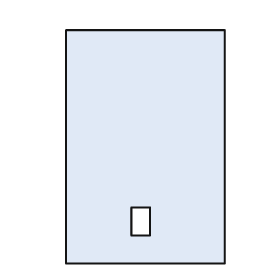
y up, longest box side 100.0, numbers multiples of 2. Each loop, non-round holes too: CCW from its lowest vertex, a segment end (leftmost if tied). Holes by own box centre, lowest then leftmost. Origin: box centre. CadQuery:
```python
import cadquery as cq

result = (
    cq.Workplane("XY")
    .moveTo(-34.0, -50.0)
    .lineTo(34.0, -50.0)
    .lineTo(34.0, 50.0)
    .lineTo(-34.0, 50.0)
    .close()
    .moveTo(-6.0, -38.0)
    .lineTo(2.0, -38.0)
    .lineTo(2.0, -26.0)
    .lineTo(-6.0, -26.0)
    .close()
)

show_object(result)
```